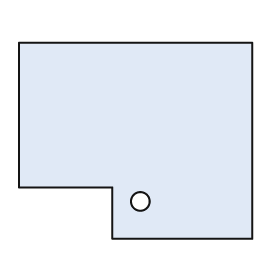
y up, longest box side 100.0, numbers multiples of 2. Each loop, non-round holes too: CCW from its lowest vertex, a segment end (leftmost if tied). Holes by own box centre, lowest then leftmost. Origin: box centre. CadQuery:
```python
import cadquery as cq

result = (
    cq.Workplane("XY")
    .moveTo(-10.0, -42.0)
    .lineTo(50.0, -42.0)
    .lineTo(50.0, 42.0)
    .lineTo(-50.0, 42.0)
    .lineTo(-50.0, -20.0)
    .lineTo(-10.0, -20.0)
    .close()
    .moveTo(2.0, -26.0)
    .circle(4.0)
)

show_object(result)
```